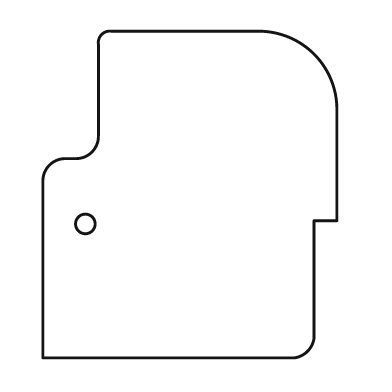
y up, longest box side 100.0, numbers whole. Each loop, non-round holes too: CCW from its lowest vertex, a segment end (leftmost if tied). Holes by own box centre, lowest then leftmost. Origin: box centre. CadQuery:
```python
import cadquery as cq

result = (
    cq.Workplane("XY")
    .moveTo(-45.0, -50.0)
    .lineTo(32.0, -50.0)
    .threePointArc((36.0, -48.0), (38.0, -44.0))
    .lineTo(38.0, -8.0)
    .lineTo(45.0, -8.0)
    .lineTo(45.0, 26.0)
    .threePointArc((38.0, 43.0), (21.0, 50.0))
    .lineTo(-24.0, 50.0)
    .threePointArc((-27.0, 49.0), (-28.0, 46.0))
    .lineTo(-28.0, 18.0)
    .threePointArc((-30.0, 13.0), (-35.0, 11.0))
    .lineTo(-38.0, 11.0)
    .threePointArc((-43.0, 9.0), (-45.0, 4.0))
    .close()
    .moveTo(-32.0, -9.0)
    .circle(3.0)
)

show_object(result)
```